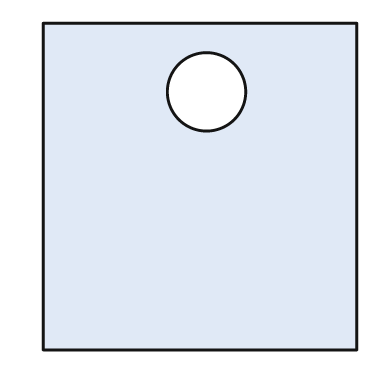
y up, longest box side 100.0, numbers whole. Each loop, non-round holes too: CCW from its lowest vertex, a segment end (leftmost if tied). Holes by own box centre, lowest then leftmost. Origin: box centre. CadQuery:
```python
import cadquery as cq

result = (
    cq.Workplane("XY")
    .moveTo(-48.0, -50.0)
    .lineTo(48.0, -50.0)
    .lineTo(48.0, 50.0)
    .lineTo(-48.0, 50.0)
    .close()
    .moveTo(2.0, 29.0)
    .circle(12.0)
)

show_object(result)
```